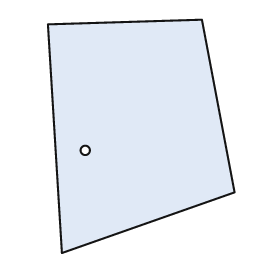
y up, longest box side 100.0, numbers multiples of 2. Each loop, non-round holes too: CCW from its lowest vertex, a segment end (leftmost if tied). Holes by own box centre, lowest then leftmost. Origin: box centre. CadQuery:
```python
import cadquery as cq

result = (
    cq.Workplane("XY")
    .moveTo(-34.0, -50.0)
    .lineTo(40.0, -24.0)
    .lineTo(26.0, 50.0)
    .lineTo(-40.0, 48.0)
    .close()
    .moveTo(-24.0, -6.0)
    .circle(2.0)
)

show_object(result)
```